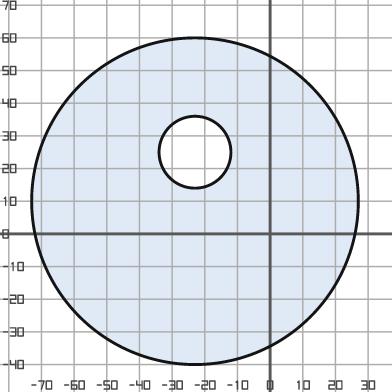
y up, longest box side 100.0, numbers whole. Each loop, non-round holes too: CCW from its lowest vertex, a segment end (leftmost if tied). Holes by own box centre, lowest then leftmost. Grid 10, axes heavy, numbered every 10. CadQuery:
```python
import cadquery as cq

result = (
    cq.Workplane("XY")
    .moveTo(-23.0, 10.0)
    .circle(50.0)
    .moveTo(-23.0, 25.0)
    .circle(11.0)
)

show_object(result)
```